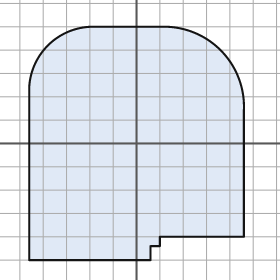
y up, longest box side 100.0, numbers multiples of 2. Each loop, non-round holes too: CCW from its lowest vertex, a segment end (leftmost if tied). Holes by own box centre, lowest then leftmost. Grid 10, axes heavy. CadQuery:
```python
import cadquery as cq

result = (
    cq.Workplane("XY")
    .moveTo(-46.0, -50.0)
    .lineTo(6.0, -50.0)
    .lineTo(6.0, -44.0)
    .lineTo(10.0, -44.0)
    .lineTo(10.0, -40.0)
    .lineTo(46.0, -40.0)
    .lineTo(46.0, 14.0)
    .threePointArc((36.0, 40.0), (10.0, 50.0))
    .lineTo(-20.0, 50.0)
    .threePointArc((-38.0, 42.0), (-46.0, 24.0))
    .close()
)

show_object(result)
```